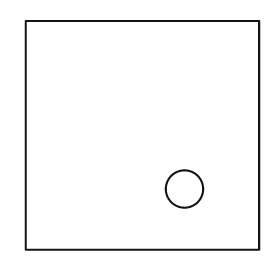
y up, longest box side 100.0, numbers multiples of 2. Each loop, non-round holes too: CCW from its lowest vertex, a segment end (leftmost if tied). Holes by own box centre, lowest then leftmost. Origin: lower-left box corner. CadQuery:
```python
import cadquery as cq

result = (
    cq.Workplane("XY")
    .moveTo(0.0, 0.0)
    .lineTo(100.0, 0.0)
    .lineTo(100.0, 98.0)
    .lineTo(0.0, 98.0)
    .close()
    .moveTo(68.0, 26.0)
    .circle(8.0)
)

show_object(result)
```